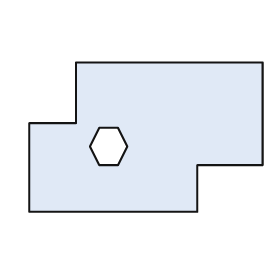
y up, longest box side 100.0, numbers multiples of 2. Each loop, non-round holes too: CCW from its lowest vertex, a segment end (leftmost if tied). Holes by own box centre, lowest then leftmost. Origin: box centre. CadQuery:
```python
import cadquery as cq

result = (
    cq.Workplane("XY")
    .moveTo(-50.0, -32.0)
    .lineTo(22.0, -32.0)
    .lineTo(22.0, -12.0)
    .lineTo(50.0, -12.0)
    .lineTo(50.0, 32.0)
    .lineTo(-30.0, 32.0)
    .lineTo(-30.0, 6.0)
    .lineTo(-50.0, 6.0)
    .close()
    .moveTo(-20.0, -12.0)
    .lineTo(-12.0, -12.0)
    .lineTo(-8.0, -4.0)
    .lineTo(-12.0, 4.0)
    .lineTo(-20.0, 4.0)
    .lineTo(-24.0, -4.0)
    .close()
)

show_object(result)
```